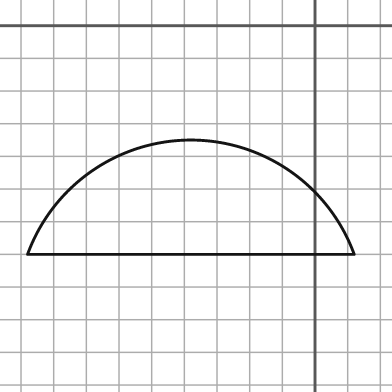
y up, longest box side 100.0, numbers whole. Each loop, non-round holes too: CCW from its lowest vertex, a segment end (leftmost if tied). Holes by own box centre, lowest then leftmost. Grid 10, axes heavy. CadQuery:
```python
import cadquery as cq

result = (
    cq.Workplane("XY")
    .moveTo(-88.0, -70.0)
    .lineTo(12.0, -70.0)
    .threePointArc((-38.0, -35.0), (-88.0, -70.0))
    .close()
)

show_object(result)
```